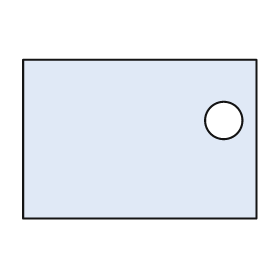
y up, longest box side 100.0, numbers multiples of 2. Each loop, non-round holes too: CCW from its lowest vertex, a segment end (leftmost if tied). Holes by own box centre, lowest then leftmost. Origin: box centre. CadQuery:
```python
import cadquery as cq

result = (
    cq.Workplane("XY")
    .moveTo(-50.0, -34.0)
    .lineTo(50.0, -34.0)
    .lineTo(50.0, 34.0)
    .lineTo(-50.0, 34.0)
    .close()
    .moveTo(36.0, 8.0)
    .circle(8.0)
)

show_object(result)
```